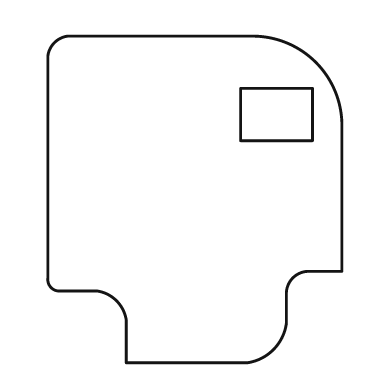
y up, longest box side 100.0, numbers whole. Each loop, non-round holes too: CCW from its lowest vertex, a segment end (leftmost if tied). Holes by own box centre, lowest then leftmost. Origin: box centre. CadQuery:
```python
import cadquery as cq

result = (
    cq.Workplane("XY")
    .moveTo(-21.0, -50.0)
    .lineTo(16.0, -50.0)
    .threePointArc((24.0, -46.0), (28.0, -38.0))
    .lineTo(28.0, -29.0)
    .threePointArc((30.0, -24.0), (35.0, -22.0))
    .lineTo(45.0, -22.0)
    .lineTo(45.0, 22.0)
    .threePointArc((37.0, 42.0), (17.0, 50.0))
    .lineTo(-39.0, 50.0)
    .threePointArc((-43.0, 48.0), (-45.0, 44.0))
    .lineTo(-45.0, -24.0)
    .threePointArc((-44.0, -27.0), (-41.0, -28.0))
    .lineTo(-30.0, -28.0)
    .threePointArc((-24.0, -31.0), (-21.0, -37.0))
    .close()
    .moveTo(14.0, 18.0)
    .lineTo(36.0, 18.0)
    .lineTo(36.0, 34.0)
    .lineTo(14.0, 34.0)
    .close()
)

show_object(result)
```